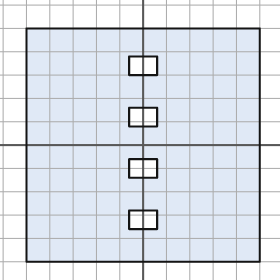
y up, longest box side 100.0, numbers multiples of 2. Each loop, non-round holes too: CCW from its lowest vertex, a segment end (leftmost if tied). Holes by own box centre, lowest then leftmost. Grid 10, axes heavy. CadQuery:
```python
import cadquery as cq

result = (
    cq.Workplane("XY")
    .moveTo(-50.0, -50.0)
    .lineTo(50.0, -50.0)
    .lineTo(50.0, 50.0)
    .lineTo(-50.0, 50.0)
    .close()
    .moveTo(-6.0, -36.0)
    .lineTo(6.0, -36.0)
    .lineTo(6.0, -28.0)
    .lineTo(-6.0, -28.0)
    .close()
    .moveTo(-6.0, -14.0)
    .lineTo(6.0, -14.0)
    .lineTo(6.0, -6.0)
    .lineTo(-6.0, -6.0)
    .close()
    .moveTo(-6.0, 8.0)
    .lineTo(6.0, 8.0)
    .lineTo(6.0, 16.0)
    .lineTo(-6.0, 16.0)
    .close()
    .moveTo(-6.0, 30.0)
    .lineTo(6.0, 30.0)
    .lineTo(6.0, 38.0)
    .lineTo(-6.0, 38.0)
    .close()
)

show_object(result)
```